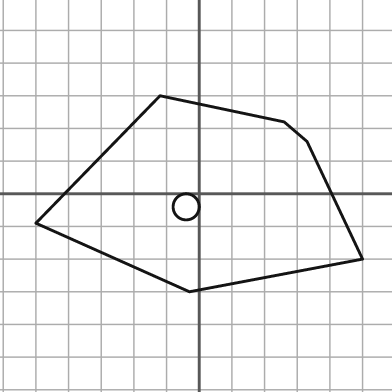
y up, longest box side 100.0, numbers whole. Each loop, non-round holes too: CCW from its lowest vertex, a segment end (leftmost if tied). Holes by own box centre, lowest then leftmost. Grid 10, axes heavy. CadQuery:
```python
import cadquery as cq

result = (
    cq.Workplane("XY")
    .moveTo(-3.0, -30.0)
    .lineTo(50.0, -20.0)
    .lineTo(33.0, 16.0)
    .lineTo(26.0, 22.0)
    .lineTo(-12.0, 30.0)
    .lineTo(-50.0, -9.0)
    .close()
    .moveTo(-4.0, -4.0)
    .circle(4.0)
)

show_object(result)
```